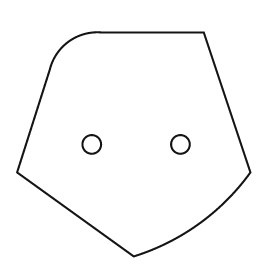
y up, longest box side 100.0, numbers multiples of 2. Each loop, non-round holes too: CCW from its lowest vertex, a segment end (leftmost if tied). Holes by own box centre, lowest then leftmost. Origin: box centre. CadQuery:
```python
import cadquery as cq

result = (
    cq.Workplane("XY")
    .moveTo(0.0, -48.0)
    .threePointArc((28.0, -34.0), (50.0, -12.0))
    .lineTo(30.0, 48.0)
    .lineTo(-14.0, 48.0)
    .threePointArc((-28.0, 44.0), (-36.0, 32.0))
    .lineTo(-50.0, -12.0)
    .close()
    .moveTo(-18.0, 0.0)
    .circle(4.0)
    .moveTo(20.0, 0.0)
    .circle(4.0)
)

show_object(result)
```